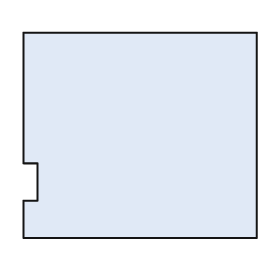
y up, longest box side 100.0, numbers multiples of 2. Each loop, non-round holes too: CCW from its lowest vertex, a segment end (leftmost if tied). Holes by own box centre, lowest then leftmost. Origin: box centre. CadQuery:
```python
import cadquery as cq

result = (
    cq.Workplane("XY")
    .moveTo(-50.0, -44.0)
    .lineTo(50.0, -44.0)
    .lineTo(50.0, 44.0)
    .lineTo(-50.0, 44.0)
    .lineTo(-50.0, -12.0)
    .lineTo(-44.0, -12.0)
    .lineTo(-44.0, -28.0)
    .lineTo(-50.0, -28.0)
    .close()
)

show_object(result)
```